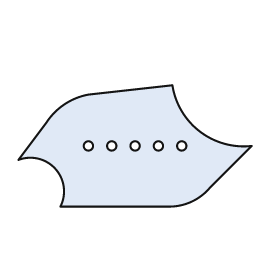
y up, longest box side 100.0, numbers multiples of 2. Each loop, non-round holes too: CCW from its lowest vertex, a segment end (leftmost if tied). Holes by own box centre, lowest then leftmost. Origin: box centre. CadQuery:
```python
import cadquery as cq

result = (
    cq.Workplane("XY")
    .moveTo(-32.0, -26.0)
    .lineTo(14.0, -26.0)
    .threePointArc((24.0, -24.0), (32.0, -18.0))
    .lineTo(50.0, 0.0)
    .threePointArc((28.0, 6.0), (16.0, 26.0))
    .lineTo(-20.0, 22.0)
    .threePointArc((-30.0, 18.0), (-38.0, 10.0))
    .lineTo(-50.0, -6.0)
    .threePointArc((-34.0, -10.0), (-32.0, -26.0))
    .close()
    .moveTo(-20.0, 0.0)
    .circle(2.0)
    .moveTo(-10.0, 0.0)
    .circle(2.0)
    .moveTo(0.0, 0.0)
    .circle(2.0)
    .moveTo(10.0, 0.0)
    .circle(2.0)
    .moveTo(20.0, 0.0)
    .circle(2.0)
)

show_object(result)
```